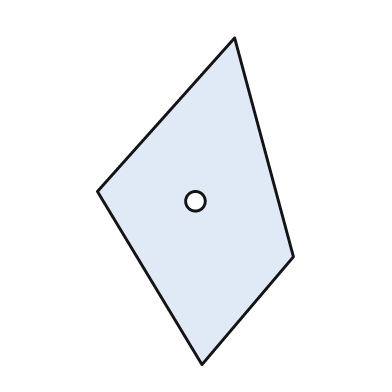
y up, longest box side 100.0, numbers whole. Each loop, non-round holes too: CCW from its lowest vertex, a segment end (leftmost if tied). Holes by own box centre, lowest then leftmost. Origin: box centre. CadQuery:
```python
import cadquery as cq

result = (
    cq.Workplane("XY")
    .moveTo(2.0, -50.0)
    .lineTo(30.0, -17.0)
    .lineTo(12.0, 50.0)
    .lineTo(-30.0, 3.0)
    .close()
    .moveTo(0.0, 0.0)
    .circle(3.0)
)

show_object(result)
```